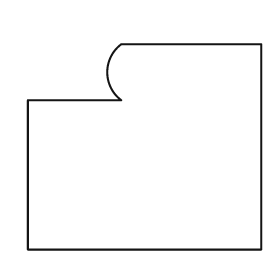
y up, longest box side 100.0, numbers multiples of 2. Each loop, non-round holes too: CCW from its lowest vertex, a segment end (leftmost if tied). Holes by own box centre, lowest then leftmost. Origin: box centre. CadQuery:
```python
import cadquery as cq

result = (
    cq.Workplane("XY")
    .moveTo(-50.0, -44.0)
    .lineTo(50.0, -44.0)
    .lineTo(50.0, 44.0)
    .lineTo(-10.0, 44.0)
    .threePointArc((-16.0, 32.0), (-10.0, 20.0))
    .lineTo(-50.0, 20.0)
    .close()
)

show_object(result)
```